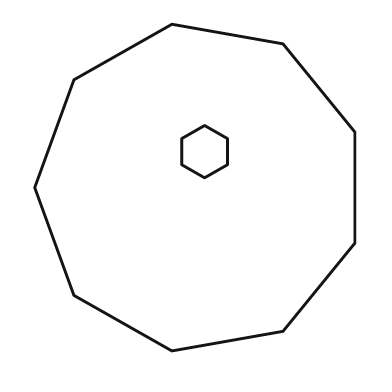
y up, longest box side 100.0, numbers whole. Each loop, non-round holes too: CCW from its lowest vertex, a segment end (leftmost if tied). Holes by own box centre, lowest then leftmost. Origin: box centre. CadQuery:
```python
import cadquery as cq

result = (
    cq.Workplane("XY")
    .moveTo(-7.0, -50.0)
    .lineTo(27.0, -44.0)
    .lineTo(49.0, -17.0)
    .lineTo(49.0, 17.0)
    .lineTo(27.0, 44.0)
    .lineTo(-7.0, 50.0)
    .lineTo(-37.0, 33.0)
    .lineTo(-49.0, 0.0)
    .lineTo(-37.0, -33.0)
    .close()
    .moveTo(3.0, 3.0)
    .lineTo(10.0, 7.0)
    .lineTo(10.0, 15.0)
    .lineTo(3.0, 19.0)
    .lineTo(-4.0, 15.0)
    .lineTo(-4.0, 7.0)
    .close()
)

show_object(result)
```